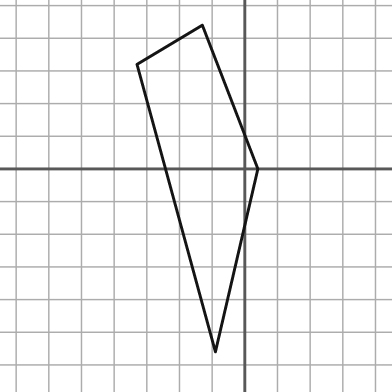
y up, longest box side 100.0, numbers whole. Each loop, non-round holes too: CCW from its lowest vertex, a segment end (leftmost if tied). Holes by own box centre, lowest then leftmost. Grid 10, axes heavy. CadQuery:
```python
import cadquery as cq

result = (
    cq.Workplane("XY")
    .moveTo(-9.0, -56.0)
    .lineTo(4.0, 0.0)
    .lineTo(-13.0, 44.0)
    .lineTo(-33.0, 32.0)
    .close()
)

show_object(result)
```